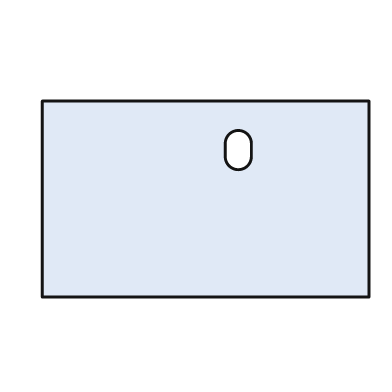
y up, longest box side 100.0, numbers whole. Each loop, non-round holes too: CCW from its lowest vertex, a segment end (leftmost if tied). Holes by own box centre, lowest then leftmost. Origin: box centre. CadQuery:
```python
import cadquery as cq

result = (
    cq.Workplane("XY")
    .moveTo(-50.0, -30.0)
    .lineTo(50.0, -30.0)
    .lineTo(50.0, 30.0)
    .lineTo(-50.0, 30.0)
    .close()
    .moveTo(6.0, 13.0)
    .threePointArc((10.0, 9.0), (14.0, 13.0))
    .lineTo(14.0, 17.0)
    .threePointArc((10.0, 21.0), (6.0, 17.0))
    .close()
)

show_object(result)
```